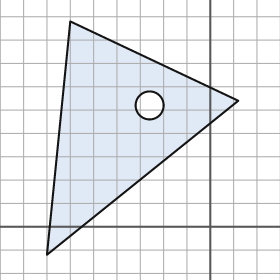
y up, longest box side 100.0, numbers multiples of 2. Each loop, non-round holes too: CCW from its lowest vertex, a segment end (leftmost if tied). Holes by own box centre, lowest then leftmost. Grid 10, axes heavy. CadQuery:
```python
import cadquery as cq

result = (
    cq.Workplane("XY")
    .moveTo(-70.0, -12.0)
    .lineTo(12.0, 54.0)
    .lineTo(-60.0, 88.0)
    .close()
    .moveTo(-26.0, 52.0)
    .circle(6.0)
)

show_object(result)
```